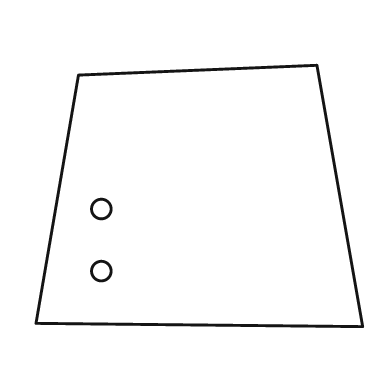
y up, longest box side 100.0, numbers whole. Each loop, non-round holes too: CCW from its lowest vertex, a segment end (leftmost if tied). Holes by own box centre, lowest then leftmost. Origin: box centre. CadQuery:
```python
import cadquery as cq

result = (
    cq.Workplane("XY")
    .moveTo(50.0, -40.0)
    .lineTo(36.0, 40.0)
    .lineTo(-37.0, 37.0)
    .lineTo(-50.0, -39.0)
    .close()
    .moveTo(-30.0, -23.0)
    .circle(3.0)
    .moveTo(-30.0, -4.0)
    .circle(3.0)
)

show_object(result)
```